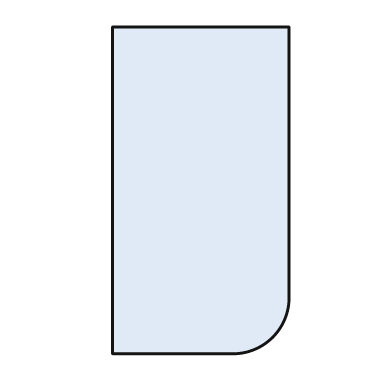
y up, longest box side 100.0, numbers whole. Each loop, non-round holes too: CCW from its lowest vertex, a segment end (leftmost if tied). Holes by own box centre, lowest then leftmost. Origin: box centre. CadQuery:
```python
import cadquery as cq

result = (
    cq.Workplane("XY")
    .moveTo(-27.0, -50.0)
    .lineTo(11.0, -50.0)
    .threePointArc((22.0, -45.0), (27.0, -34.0))
    .lineTo(27.0, 50.0)
    .lineTo(-27.0, 50.0)
    .close()
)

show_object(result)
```